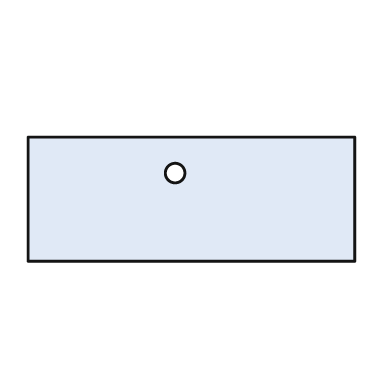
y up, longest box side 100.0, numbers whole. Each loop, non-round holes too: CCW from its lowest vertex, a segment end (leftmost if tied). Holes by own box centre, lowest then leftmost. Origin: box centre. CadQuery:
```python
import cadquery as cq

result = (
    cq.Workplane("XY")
    .moveTo(-50.0, -19.0)
    .lineTo(50.0, -19.0)
    .lineTo(50.0, 19.0)
    .lineTo(-50.0, 19.0)
    .close()
    .moveTo(-5.0, 8.0)
    .circle(3.0)
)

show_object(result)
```